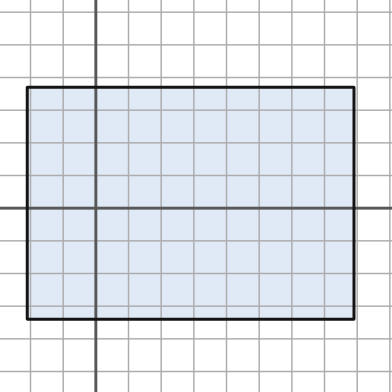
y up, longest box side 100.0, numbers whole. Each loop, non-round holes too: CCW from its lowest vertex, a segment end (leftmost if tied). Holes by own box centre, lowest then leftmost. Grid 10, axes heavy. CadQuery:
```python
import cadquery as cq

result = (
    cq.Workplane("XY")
    .moveTo(-21.0, -34.0)
    .lineTo(79.0, -34.0)
    .lineTo(79.0, 37.0)
    .lineTo(-21.0, 37.0)
    .close()
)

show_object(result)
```